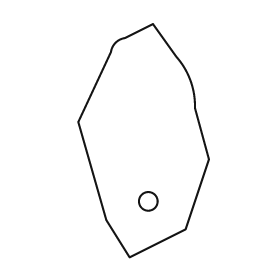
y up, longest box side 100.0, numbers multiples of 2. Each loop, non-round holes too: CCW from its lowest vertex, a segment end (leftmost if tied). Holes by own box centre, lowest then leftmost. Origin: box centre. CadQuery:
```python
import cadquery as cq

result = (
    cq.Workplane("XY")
    .moveTo(-6.0, -50.0)
    .lineTo(18.0, -38.0)
    .lineTo(28.0, -8.0)
    .lineTo(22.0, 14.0)
    .threePointArc((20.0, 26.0), (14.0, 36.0))
    .lineTo(4.0, 50.0)
    .lineTo(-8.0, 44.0)
    .threePointArc((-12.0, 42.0), (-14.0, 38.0))
    .lineTo(-28.0, 8.0)
    .lineTo(-16.0, -34.0)
    .close()
    .moveTo(2.0, -26.0)
    .circle(4.0)
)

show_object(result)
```